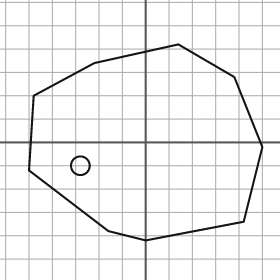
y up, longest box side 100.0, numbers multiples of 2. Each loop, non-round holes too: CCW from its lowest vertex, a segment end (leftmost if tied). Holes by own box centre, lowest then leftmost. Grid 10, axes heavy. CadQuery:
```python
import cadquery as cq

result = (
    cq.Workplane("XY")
    .moveTo(0.0, -42.0)
    .lineTo(42.0, -34.0)
    .lineTo(50.0, -2.0)
    .lineTo(38.0, 28.0)
    .lineTo(14.0, 42.0)
    .lineTo(-22.0, 34.0)
    .lineTo(-48.0, 20.0)
    .lineTo(-50.0, -12.0)
    .lineTo(-16.0, -38.0)
    .close()
    .moveTo(-28.0, -10.0)
    .circle(4.0)
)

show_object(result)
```